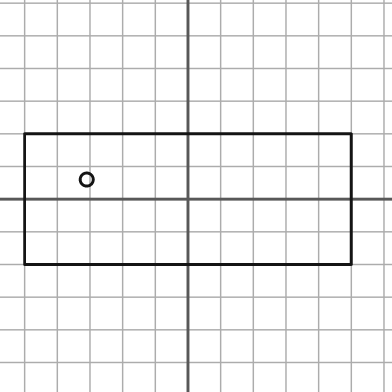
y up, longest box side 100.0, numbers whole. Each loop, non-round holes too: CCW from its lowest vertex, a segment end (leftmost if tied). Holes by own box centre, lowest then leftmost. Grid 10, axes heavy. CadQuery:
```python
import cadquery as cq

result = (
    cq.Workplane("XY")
    .moveTo(-50.0, -20.0)
    .lineTo(50.0, -20.0)
    .lineTo(50.0, 20.0)
    .lineTo(-50.0, 20.0)
    .close()
    .moveTo(-31.0, 6.0)
    .circle(2.0)
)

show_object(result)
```